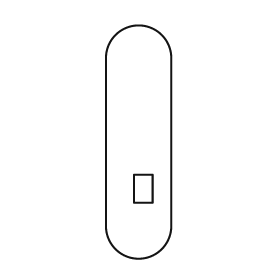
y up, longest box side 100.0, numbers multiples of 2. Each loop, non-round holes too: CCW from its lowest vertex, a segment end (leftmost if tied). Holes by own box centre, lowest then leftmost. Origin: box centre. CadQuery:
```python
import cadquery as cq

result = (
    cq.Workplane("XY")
    .moveTo(-14.0, -36.0)
    .threePointArc((0.0, -50.0), (14.0, -36.0))
    .lineTo(14.0, 36.0)
    .threePointArc((0.0, 50.0), (-14.0, 36.0))
    .close()
    .moveTo(-2.0, -26.0)
    .lineTo(6.0, -26.0)
    .lineTo(6.0, -14.0)
    .lineTo(-2.0, -14.0)
    .close()
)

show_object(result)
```